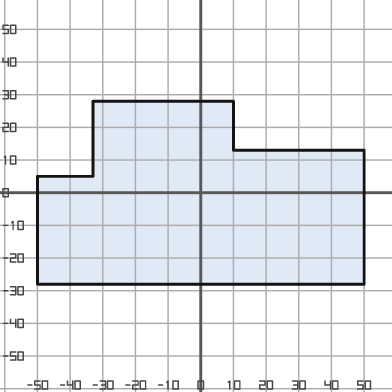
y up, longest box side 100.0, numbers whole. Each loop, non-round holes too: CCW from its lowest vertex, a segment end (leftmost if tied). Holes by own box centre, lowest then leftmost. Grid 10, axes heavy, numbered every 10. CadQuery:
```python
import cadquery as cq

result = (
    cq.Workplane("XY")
    .moveTo(-50.0, -28.0)
    .lineTo(50.0, -28.0)
    .lineTo(50.0, 13.0)
    .lineTo(10.0, 13.0)
    .lineTo(10.0, 28.0)
    .lineTo(-33.0, 28.0)
    .lineTo(-33.0, 5.0)
    .lineTo(-50.0, 5.0)
    .close()
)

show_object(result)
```